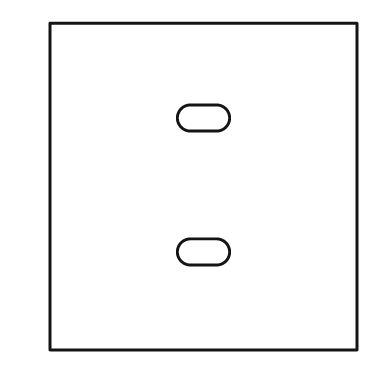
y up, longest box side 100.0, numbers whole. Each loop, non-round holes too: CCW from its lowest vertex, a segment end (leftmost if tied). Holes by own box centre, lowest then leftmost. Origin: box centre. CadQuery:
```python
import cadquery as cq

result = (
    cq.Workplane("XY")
    .moveTo(-47.0, -50.0)
    .lineTo(47.0, -50.0)
    .lineTo(47.0, 50.0)
    .lineTo(-47.0, 50.0)
    .close()
    .moveTo(-4.0, -24.0)
    .lineTo(4.0, -24.0)
    .threePointArc((8.0, -20.0), (4.0, -16.0))
    .lineTo(-4.0, -16.0)
    .threePointArc((-8.0, -20.0), (-4.0, -24.0))
    .close()
    .moveTo(-4.0, 17.0)
    .lineTo(4.0, 17.0)
    .threePointArc((8.0, 21.0), (4.0, 25.0))
    .lineTo(-4.0, 25.0)
    .threePointArc((-8.0, 21.0), (-4.0, 17.0))
    .close()
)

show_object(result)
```